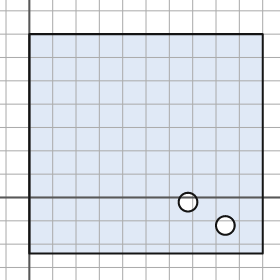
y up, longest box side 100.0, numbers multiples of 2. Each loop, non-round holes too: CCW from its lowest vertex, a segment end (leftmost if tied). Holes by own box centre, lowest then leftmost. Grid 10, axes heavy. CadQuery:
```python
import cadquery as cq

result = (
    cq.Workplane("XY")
    .moveTo(0.0, -24.0)
    .lineTo(100.0, -24.0)
    .lineTo(100.0, 70.0)
    .lineTo(0.0, 70.0)
    .close()
    .moveTo(84.0, -12.0)
    .circle(4.0)
    .moveTo(68.0, -2.0)
    .circle(4.0)
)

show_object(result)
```